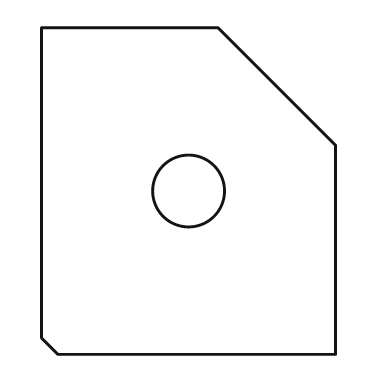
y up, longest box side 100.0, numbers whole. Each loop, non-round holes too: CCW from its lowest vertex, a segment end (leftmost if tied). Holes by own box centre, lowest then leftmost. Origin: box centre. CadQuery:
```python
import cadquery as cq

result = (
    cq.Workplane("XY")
    .moveTo(-40.0, -50.0)
    .lineTo(45.0, -50.0)
    .lineTo(45.0, 14.0)
    .lineTo(9.0, 50.0)
    .lineTo(-45.0, 50.0)
    .lineTo(-45.0, -45.0)
    .close()
    .moveTo(0.0, 0.0)
    .circle(11.0)
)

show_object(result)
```